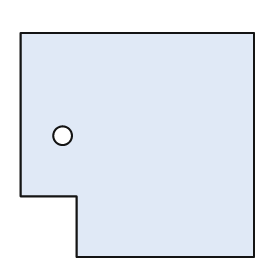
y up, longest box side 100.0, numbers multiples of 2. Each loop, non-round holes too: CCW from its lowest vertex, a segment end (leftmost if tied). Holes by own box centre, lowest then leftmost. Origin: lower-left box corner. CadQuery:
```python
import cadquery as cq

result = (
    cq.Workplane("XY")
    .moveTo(24.0, 0.0)
    .lineTo(100.0, 0.0)
    .lineTo(100.0, 96.0)
    .lineTo(0.0, 96.0)
    .lineTo(0.0, 26.0)
    .lineTo(24.0, 26.0)
    .close()
    .moveTo(18.0, 52.0)
    .circle(4.0)
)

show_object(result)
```